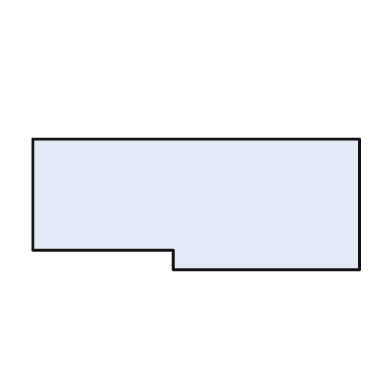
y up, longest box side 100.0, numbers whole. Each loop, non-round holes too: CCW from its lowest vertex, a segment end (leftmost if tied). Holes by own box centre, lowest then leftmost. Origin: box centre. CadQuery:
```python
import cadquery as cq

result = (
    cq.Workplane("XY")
    .moveTo(-7.0, -20.0)
    .lineTo(50.0, -20.0)
    .lineTo(50.0, 20.0)
    .lineTo(-50.0, 20.0)
    .lineTo(-50.0, -14.0)
    .lineTo(-7.0, -14.0)
    .close()
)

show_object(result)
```